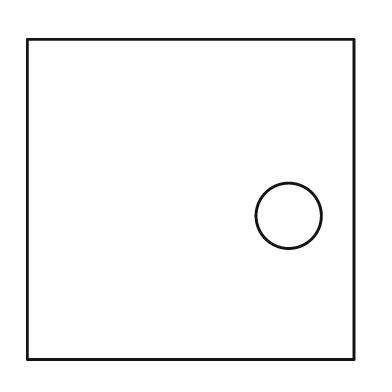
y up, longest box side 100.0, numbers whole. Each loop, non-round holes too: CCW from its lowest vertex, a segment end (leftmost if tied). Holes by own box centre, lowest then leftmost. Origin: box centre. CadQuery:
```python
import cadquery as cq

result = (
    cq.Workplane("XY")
    .moveTo(-50.0, -49.0)
    .lineTo(50.0, -49.0)
    .lineTo(50.0, 49.0)
    .lineTo(-50.0, 49.0)
    .close()
    .moveTo(30.0, -5.0)
    .circle(10.0)
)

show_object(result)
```